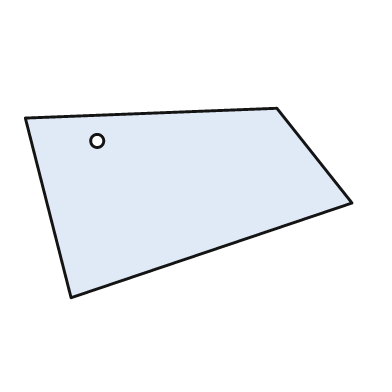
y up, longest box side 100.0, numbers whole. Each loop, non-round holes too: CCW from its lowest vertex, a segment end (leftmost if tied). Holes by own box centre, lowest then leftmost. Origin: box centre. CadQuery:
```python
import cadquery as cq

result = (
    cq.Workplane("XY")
    .moveTo(-36.0, -29.0)
    .lineTo(50.0, 0.0)
    .lineTo(27.0, 29.0)
    .lineTo(-50.0, 26.0)
    .close()
    .moveTo(-28.0, 19.0)
    .circle(2.0)
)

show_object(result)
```